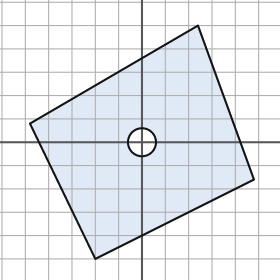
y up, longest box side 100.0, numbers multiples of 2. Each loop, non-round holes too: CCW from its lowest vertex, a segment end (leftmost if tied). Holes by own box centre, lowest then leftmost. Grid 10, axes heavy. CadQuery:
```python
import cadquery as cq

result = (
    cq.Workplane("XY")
    .moveTo(-20.0, -50.0)
    .lineTo(48.0, -16.0)
    .lineTo(24.0, 50.0)
    .lineTo(-48.0, 8.0)
    .close()
    .moveTo(0.0, 0.0)
    .circle(6.0)
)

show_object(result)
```